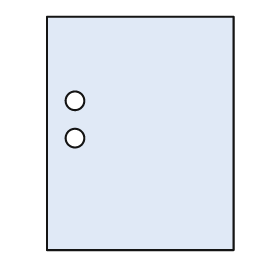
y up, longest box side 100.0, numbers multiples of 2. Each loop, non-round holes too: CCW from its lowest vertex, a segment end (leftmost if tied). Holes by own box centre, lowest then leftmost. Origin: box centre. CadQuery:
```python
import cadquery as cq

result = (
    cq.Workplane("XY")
    .moveTo(-40.0, -50.0)
    .lineTo(40.0, -50.0)
    .lineTo(40.0, 50.0)
    .lineTo(-40.0, 50.0)
    .close()
    .moveTo(-28.0, -2.0)
    .circle(4.0)
    .moveTo(-28.0, 14.0)
    .circle(4.0)
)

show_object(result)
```